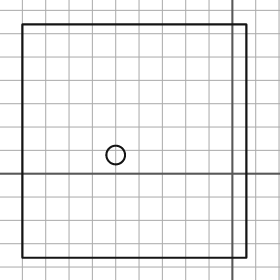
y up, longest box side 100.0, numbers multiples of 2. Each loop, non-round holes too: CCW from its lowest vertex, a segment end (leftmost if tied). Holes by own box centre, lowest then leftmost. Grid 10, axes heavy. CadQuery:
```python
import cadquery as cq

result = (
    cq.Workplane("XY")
    .moveTo(-90.0, -36.0)
    .lineTo(6.0, -36.0)
    .lineTo(6.0, 64.0)
    .lineTo(-90.0, 64.0)
    .close()
    .moveTo(-50.0, 8.0)
    .circle(4.0)
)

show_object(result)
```